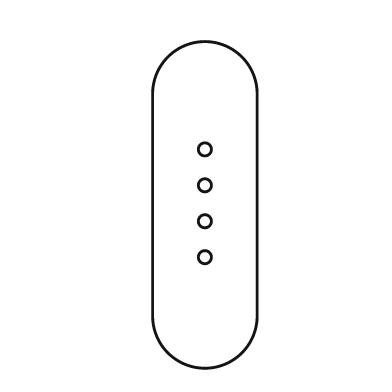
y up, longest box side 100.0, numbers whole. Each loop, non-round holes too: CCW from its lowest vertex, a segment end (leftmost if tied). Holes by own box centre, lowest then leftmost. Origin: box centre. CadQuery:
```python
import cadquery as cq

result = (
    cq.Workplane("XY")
    .moveTo(-16.0, -34.0)
    .threePointArc((0.0, -50.0), (16.0, -34.0))
    .lineTo(16.0, 34.0)
    .threePointArc((0.0, 50.0), (-16.0, 34.0))
    .close()
    .moveTo(0.0, -16.0)
    .circle(2.0)
    .moveTo(0.0, -5.0)
    .circle(2.0)
    .moveTo(0.0, 6.0)
    .circle(2.0)
    .moveTo(0.0, 17.0)
    .circle(2.0)
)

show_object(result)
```